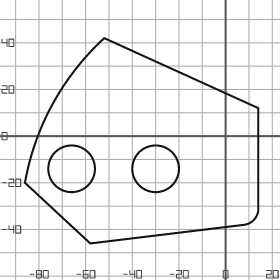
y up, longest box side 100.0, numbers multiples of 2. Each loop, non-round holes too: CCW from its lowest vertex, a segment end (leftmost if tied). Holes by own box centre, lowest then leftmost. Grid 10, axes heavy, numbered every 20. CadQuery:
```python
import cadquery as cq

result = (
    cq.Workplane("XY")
    .moveTo(-58.0, -46.0)
    .lineTo(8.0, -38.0)
    .threePointArc((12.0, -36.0), (14.0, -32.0))
    .lineTo(14.0, 12.0)
    .lineTo(-52.0, 42.0)
    .threePointArc((-74.0, 14.0), (-86.0, -20.0))
    .close()
    .moveTo(-66.0, -14.0)
    .circle(10.0)
    .moveTo(-30.0, -14.0)
    .circle(10.0)
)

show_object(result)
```